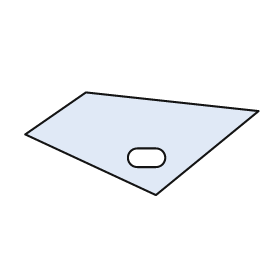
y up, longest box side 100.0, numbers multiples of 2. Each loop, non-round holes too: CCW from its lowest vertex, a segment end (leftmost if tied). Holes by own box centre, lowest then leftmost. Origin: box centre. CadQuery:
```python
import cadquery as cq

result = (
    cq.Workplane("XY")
    .moveTo(6.0, -22.0)
    .lineTo(50.0, 14.0)
    .lineTo(-24.0, 22.0)
    .lineTo(-50.0, 4.0)
    .close()
    .moveTo(-2.0, -10.0)
    .lineTo(6.0, -10.0)
    .threePointArc((10.0, -6.0), (6.0, -2.0))
    .lineTo(-2.0, -2.0)
    .threePointArc((-6.0, -6.0), (-2.0, -10.0))
    .close()
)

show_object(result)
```